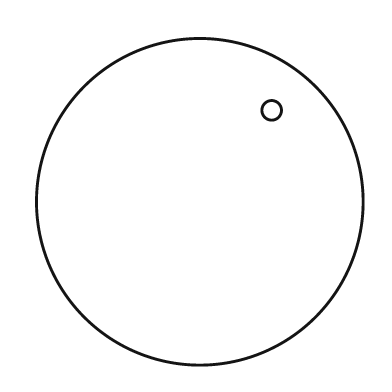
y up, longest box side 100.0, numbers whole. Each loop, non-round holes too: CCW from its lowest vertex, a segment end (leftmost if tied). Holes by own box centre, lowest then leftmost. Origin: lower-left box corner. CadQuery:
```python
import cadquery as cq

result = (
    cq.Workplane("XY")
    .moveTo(50.0, 50.0)
    .circle(50.0)
    .moveTo(72.0, 78.0)
    .circle(3.0)
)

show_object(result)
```